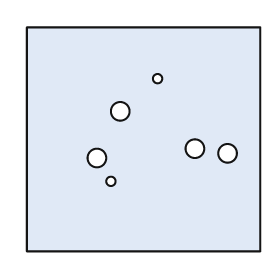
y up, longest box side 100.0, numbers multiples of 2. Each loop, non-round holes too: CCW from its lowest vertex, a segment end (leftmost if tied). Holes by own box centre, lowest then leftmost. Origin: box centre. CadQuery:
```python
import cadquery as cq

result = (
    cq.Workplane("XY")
    .moveTo(-50.0, -48.0)
    .lineTo(50.0, -48.0)
    .lineTo(50.0, 48.0)
    .lineTo(-50.0, 48.0)
    .close()
    .moveTo(-14.0, -18.0)
    .circle(2.0)
    .moveTo(-20.0, -8.0)
    .circle(4.0)
    .moveTo(36.0, -6.0)
    .circle(4.0)
    .moveTo(22.0, -4.0)
    .circle(4.0)
    .moveTo(-10.0, 12.0)
    .circle(4.0)
    .moveTo(6.0, 26.0)
    .circle(2.0)
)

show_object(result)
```